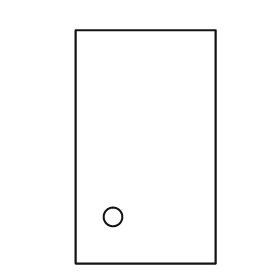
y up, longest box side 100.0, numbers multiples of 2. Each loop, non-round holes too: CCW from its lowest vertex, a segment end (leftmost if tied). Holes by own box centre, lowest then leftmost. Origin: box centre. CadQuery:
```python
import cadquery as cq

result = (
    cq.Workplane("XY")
    .moveTo(-30.0, -50.0)
    .lineTo(30.0, -50.0)
    .lineTo(30.0, 50.0)
    .lineTo(-30.0, 50.0)
    .close()
    .moveTo(-14.0, -30.0)
    .circle(4.0)
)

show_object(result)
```